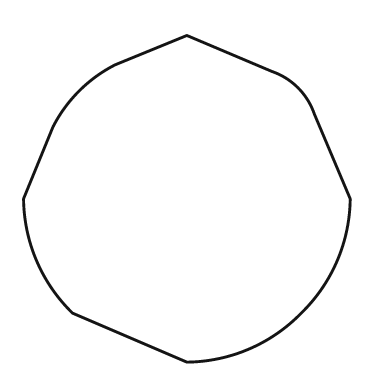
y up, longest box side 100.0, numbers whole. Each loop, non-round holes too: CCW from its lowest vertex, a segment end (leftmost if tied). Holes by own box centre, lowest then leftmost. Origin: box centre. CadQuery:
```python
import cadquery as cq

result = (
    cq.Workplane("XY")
    .moveTo(0.0, -50.0)
    .threePointArc((19.0, -46.0), (35.0, -35.0))
    .threePointArc((46.0, -19.0), (50.0, 0.0))
    .lineTo(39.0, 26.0)
    .threePointArc((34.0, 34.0), (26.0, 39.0))
    .lineTo(0.0, 50.0)
    .lineTo(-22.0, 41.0)
    .threePointArc((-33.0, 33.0), (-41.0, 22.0))
    .lineTo(-50.0, 0.0)
    .threePointArc((-46.0, -19.0), (-35.0, -35.0))
    .close()
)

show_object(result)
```